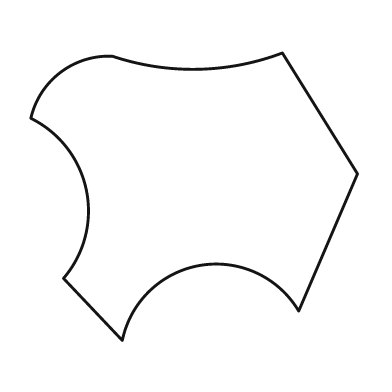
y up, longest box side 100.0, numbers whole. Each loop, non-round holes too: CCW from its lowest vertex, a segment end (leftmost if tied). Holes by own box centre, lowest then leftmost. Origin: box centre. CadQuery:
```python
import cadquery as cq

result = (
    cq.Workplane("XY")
    .moveTo(-22.0, -44.0)
    .threePointArc((2.0, -21.0), (32.0, -35.0))
    .lineTo(50.0, 7.0)
    .lineTo(27.0, 44.0)
    .threePointArc((1.0, 39.0), (-25.0, 43.0))
    .threePointArc((-41.0, 38.0), (-50.0, 24.0))
    .threePointArc((-33.0, 2.0), (-40.0, -25.0))
    .close()
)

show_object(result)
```